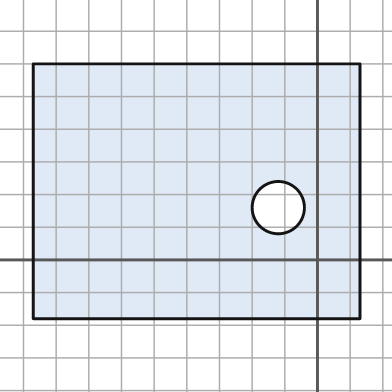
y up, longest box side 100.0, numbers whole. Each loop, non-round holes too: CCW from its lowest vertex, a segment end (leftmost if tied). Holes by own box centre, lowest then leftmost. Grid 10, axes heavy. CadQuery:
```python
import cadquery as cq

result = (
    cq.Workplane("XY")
    .moveTo(-87.0, -18.0)
    .lineTo(13.0, -18.0)
    .lineTo(13.0, 60.0)
    .lineTo(-87.0, 60.0)
    .close()
    .moveTo(-12.0, 16.0)
    .circle(8.0)
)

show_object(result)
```